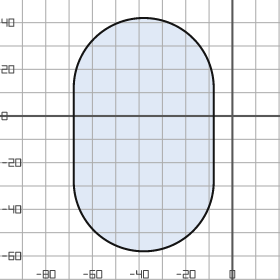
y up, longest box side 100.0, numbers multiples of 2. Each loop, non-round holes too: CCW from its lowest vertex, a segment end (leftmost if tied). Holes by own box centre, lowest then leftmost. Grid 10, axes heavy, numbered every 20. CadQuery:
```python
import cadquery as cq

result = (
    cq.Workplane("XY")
    .moveTo(-68.0, -28.0)
    .threePointArc((-38.0, -58.0), (-8.0, -28.0))
    .lineTo(-8.0, 12.0)
    .threePointArc((-38.0, 42.0), (-68.0, 12.0))
    .close()
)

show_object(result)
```